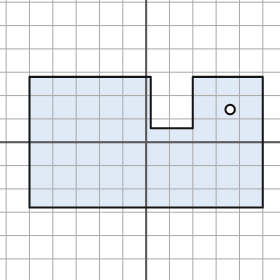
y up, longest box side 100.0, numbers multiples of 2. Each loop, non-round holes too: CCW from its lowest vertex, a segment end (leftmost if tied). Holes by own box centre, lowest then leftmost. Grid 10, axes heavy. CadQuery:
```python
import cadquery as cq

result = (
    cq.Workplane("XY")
    .moveTo(-50.0, -28.0)
    .lineTo(50.0, -28.0)
    .lineTo(50.0, 28.0)
    .lineTo(20.0, 28.0)
    .lineTo(20.0, 6.0)
    .lineTo(2.0, 6.0)
    .lineTo(2.0, 28.0)
    .lineTo(-50.0, 28.0)
    .close()
    .moveTo(36.0, 14.0)
    .circle(2.0)
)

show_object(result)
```